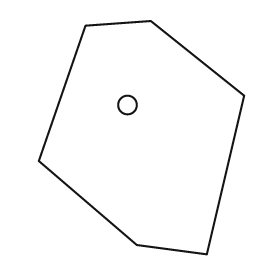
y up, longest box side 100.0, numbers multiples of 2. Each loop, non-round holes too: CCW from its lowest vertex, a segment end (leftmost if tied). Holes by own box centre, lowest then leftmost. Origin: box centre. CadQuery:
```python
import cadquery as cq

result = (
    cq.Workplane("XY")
    .moveTo(28.0, -50.0)
    .lineTo(44.0, 18.0)
    .lineTo(4.0, 50.0)
    .lineTo(-24.0, 48.0)
    .lineTo(-44.0, -10.0)
    .lineTo(-2.0, -46.0)
    .close()
    .moveTo(-6.0, 14.0)
    .circle(4.0)
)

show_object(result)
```